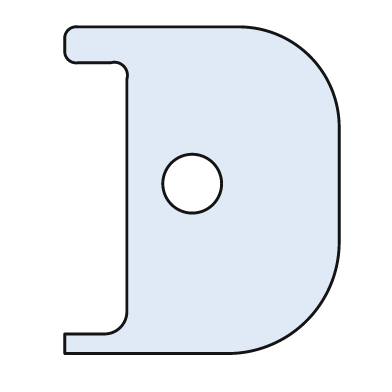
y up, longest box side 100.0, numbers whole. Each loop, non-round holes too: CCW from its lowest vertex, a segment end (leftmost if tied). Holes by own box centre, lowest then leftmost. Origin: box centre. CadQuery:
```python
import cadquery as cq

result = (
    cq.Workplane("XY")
    .moveTo(-42.0, -50.0)
    .lineTo(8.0, -50.0)
    .threePointArc((32.0, -40.0), (42.0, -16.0))
    .lineTo(42.0, 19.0)
    .threePointArc((33.0, 41.0), (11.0, 50.0))
    .lineTo(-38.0, 50.0)
    .threePointArc((-41.0, 49.0), (-42.0, 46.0))
    .lineTo(-42.0, 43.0)
    .threePointArc((-41.0, 40.0), (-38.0, 39.0))
    .lineTo(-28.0, 39.0)
    .threePointArc((-24.0, 38.0), (-23.0, 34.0))
    .lineTo(-23.0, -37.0)
    .threePointArc((-25.0, -42.0), (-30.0, -44.0))
    .lineTo(-42.0, -44.0)
    .close()
    .moveTo(-3.0, 2.0)
    .circle(9.0)
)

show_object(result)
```